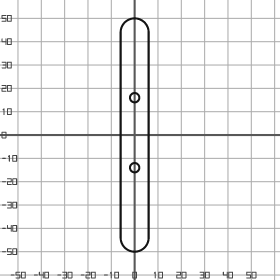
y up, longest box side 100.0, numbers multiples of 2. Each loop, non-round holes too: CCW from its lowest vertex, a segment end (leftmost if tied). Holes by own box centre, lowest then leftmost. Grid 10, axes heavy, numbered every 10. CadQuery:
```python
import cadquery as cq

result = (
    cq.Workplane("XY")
    .moveTo(-6.0, -44.0)
    .threePointArc((0.0, -50.0), (6.0, -44.0))
    .lineTo(6.0, 44.0)
    .threePointArc((0.0, 50.0), (-6.0, 44.0))
    .close()
    .moveTo(0.0, -14.0)
    .circle(2.0)
    .moveTo(0.0, 16.0)
    .circle(2.0)
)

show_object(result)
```